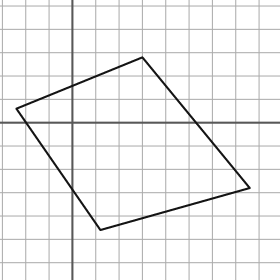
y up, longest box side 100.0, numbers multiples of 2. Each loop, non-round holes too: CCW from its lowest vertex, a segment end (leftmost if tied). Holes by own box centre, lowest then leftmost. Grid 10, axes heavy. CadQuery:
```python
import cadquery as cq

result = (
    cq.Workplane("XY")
    .moveTo(12.0, -46.0)
    .lineTo(76.0, -28.0)
    .lineTo(30.0, 28.0)
    .lineTo(-24.0, 6.0)
    .close()
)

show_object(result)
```